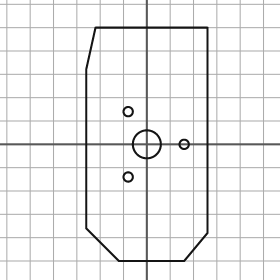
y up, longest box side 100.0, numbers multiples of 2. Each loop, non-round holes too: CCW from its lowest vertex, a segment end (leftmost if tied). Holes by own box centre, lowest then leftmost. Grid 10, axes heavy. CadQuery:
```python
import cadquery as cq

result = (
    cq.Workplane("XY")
    .moveTo(-12.0, -50.0)
    .lineTo(16.0, -50.0)
    .lineTo(26.0, -38.0)
    .lineTo(26.0, 50.0)
    .lineTo(-22.0, 50.0)
    .lineTo(-26.0, 32.0)
    .lineTo(-26.0, -36.0)
    .close()
    .moveTo(-8.0, -14.0)
    .circle(2.0)
    .moveTo(0.0, 0.0)
    .circle(6.0)
    .moveTo(16.0, 0.0)
    .circle(2.0)
    .moveTo(-8.0, 14.0)
    .circle(2.0)
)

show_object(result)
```